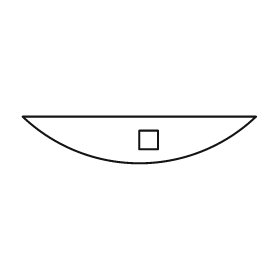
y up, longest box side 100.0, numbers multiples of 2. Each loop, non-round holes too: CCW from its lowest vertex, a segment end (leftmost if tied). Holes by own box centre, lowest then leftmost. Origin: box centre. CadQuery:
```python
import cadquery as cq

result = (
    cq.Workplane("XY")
    .moveTo(-50.0, 10.0)
    .threePointArc((0.0, -10.0), (50.0, 10.0))
    .close()
    .moveTo(0.0, -4.0)
    .lineTo(8.0, -4.0)
    .lineTo(8.0, 4.0)
    .lineTo(0.0, 4.0)
    .close()
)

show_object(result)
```